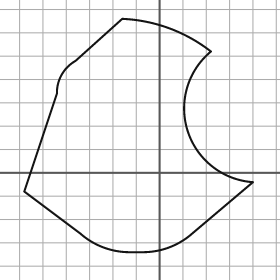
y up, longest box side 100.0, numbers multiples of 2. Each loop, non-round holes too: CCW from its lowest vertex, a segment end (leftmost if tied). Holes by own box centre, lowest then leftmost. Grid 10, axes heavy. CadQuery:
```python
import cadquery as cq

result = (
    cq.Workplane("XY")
    .moveTo(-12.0, -34.0)
    .lineTo(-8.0, -34.0)
    .threePointArc((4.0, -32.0), (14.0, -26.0))
    .lineTo(40.0, -4.0)
    .threePointArc((12.0, 18.0), (22.0, 52.0))
    .threePointArc((4.0, 62.0), (-16.0, 66.0))
    .lineTo(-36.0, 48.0)
    .threePointArc((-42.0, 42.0), (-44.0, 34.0))
    .lineTo(-58.0, -8.0)
    .lineTo(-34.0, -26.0)
    .threePointArc((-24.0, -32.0), (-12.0, -34.0))
    .close()
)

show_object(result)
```